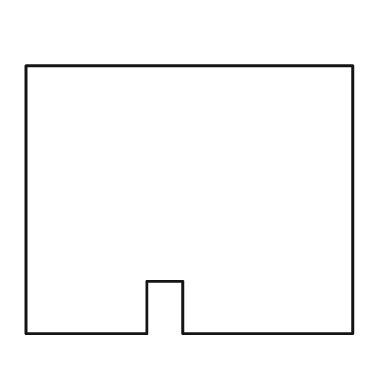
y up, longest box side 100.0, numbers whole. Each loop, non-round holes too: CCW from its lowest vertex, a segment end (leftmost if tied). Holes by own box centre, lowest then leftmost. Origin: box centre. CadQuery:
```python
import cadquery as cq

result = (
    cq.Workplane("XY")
    .moveTo(-50.0, -41.0)
    .lineTo(-13.0, -41.0)
    .lineTo(-13.0, -25.0)
    .lineTo(-2.0, -25.0)
    .lineTo(-2.0, -41.0)
    .lineTo(50.0, -41.0)
    .lineTo(50.0, 41.0)
    .lineTo(-50.0, 41.0)
    .close()
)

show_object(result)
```